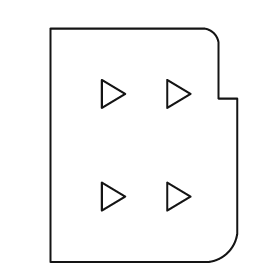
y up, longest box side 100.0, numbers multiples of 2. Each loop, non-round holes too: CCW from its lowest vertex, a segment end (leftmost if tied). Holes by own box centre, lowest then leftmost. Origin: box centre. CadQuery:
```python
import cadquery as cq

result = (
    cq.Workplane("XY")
    .moveTo(-40.0, -50.0)
    .lineTo(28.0, -50.0)
    .threePointArc((36.0, -46.0), (40.0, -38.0))
    .lineTo(40.0, 20.0)
    .lineTo(32.0, 20.0)
    .lineTo(32.0, 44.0)
    .threePointArc((30.0, 48.0), (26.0, 50.0))
    .lineTo(-40.0, 50.0)
    .close()
    .moveTo(-18.0, -28.0)
    .lineTo(-8.0, -22.0)
    .lineTo(-18.0, -16.0)
    .close()
    .moveTo(10.0, -28.0)
    .lineTo(20.0, -22.0)
    .lineTo(10.0, -16.0)
    .close()
    .moveTo(-18.0, 16.0)
    .lineTo(-8.0, 22.0)
    .lineTo(-18.0, 28.0)
    .close()
    .moveTo(10.0, 16.0)
    .lineTo(20.0, 22.0)
    .lineTo(10.0, 28.0)
    .close()
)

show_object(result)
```